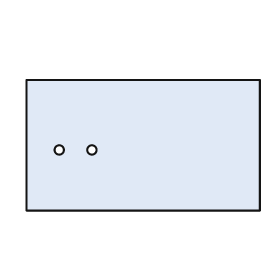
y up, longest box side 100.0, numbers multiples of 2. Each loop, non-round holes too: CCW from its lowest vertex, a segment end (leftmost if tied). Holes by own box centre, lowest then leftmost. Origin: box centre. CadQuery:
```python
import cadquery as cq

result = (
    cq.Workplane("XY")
    .moveTo(-50.0, -28.0)
    .lineTo(50.0, -28.0)
    .lineTo(50.0, 28.0)
    .lineTo(-50.0, 28.0)
    .close()
    .moveTo(-36.0, -2.0)
    .circle(2.0)
    .moveTo(-22.0, -2.0)
    .circle(2.0)
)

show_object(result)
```